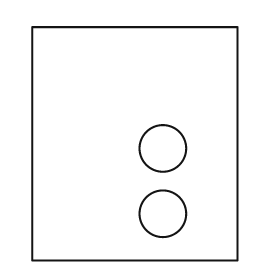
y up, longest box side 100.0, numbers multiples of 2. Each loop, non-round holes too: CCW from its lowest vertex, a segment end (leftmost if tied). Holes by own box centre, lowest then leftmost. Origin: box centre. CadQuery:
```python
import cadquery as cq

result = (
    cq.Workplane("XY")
    .moveTo(-44.0, -50.0)
    .lineTo(44.0, -50.0)
    .lineTo(44.0, 50.0)
    .lineTo(-44.0, 50.0)
    .close()
    .moveTo(12.0, -30.0)
    .circle(10.0)
    .moveTo(12.0, -2.0)
    .circle(10.0)
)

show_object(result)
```